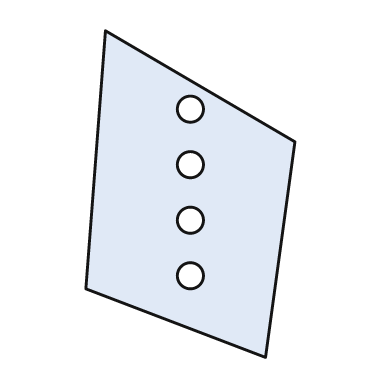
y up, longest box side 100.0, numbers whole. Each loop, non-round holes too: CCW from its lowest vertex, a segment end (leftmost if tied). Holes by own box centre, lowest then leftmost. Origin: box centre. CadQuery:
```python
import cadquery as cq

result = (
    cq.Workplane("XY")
    .moveTo(23.0, -50.0)
    .lineTo(32.0, 16.0)
    .lineTo(-26.0, 50.0)
    .lineTo(-32.0, -29.0)
    .close()
    .moveTo(0.0, -25.0)
    .circle(4.0)
    .moveTo(0.0, -8.0)
    .circle(4.0)
    .moveTo(0.0, 9.0)
    .circle(4.0)
    .moveTo(0.0, 26.0)
    .circle(4.0)
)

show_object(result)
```